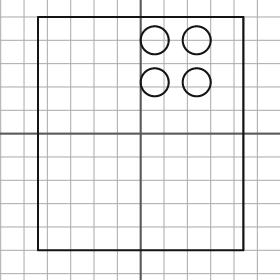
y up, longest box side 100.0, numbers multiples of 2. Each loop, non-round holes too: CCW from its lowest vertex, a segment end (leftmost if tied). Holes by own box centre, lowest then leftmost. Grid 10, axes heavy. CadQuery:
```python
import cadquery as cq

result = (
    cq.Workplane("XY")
    .moveTo(-44.0, -50.0)
    .lineTo(44.0, -50.0)
    .lineTo(44.0, 50.0)
    .lineTo(-44.0, 50.0)
    .close()
    .moveTo(6.0, 22.0)
    .circle(6.0)
    .moveTo(24.0, 22.0)
    .circle(6.0)
    .moveTo(6.0, 40.0)
    .circle(6.0)
    .moveTo(24.0, 40.0)
    .circle(6.0)
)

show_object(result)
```